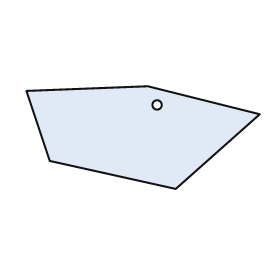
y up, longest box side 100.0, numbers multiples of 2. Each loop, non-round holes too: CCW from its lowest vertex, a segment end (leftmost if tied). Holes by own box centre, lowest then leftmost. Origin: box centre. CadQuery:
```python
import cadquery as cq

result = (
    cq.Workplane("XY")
    .moveTo(14.0, -22.0)
    .lineTo(50.0, 10.0)
    .lineTo(2.0, 22.0)
    .lineTo(-50.0, 20.0)
    .lineTo(-40.0, -10.0)
    .close()
    .moveTo(6.0, 14.0)
    .circle(2.0)
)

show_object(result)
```